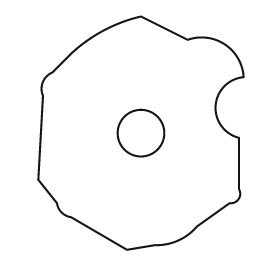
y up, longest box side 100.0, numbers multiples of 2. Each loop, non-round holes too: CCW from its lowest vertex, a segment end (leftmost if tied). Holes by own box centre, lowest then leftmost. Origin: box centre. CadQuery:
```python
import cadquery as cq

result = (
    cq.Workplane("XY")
    .moveTo(-6.0, -50.0)
    .lineTo(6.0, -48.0)
    .threePointArc((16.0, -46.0), (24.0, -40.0))
    .lineTo(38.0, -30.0)
    .threePointArc((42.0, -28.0), (42.0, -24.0))
    .lineTo(42.0, -2.0)
    .threePointArc((32.0, 12.0), (44.0, 24.0))
    .threePointArc((36.0, 38.0), (20.0, 40.0))
    .lineTo(0.0, 50.0)
    .threePointArc((-16.0, 44.0), (-30.0, 34.0))
    .lineTo(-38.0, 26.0)
    .threePointArc((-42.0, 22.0), (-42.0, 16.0))
    .lineTo(-44.0, -20.0)
    .lineTo(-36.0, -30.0)
    .threePointArc((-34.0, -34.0), (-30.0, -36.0))
    .close()
    .moveTo(0.0, 0.0)
    .circle(10.0)
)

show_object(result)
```